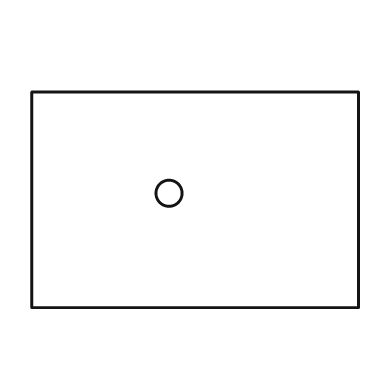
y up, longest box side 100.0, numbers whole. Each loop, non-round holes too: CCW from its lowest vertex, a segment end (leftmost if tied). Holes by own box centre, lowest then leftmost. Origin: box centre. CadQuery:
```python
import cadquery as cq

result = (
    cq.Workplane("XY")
    .moveTo(-50.0, -33.0)
    .lineTo(50.0, -33.0)
    .lineTo(50.0, 33.0)
    .lineTo(-50.0, 33.0)
    .close()
    .moveTo(-8.0, 2.0)
    .circle(4.0)
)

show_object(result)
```